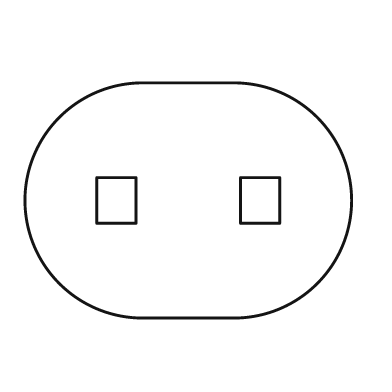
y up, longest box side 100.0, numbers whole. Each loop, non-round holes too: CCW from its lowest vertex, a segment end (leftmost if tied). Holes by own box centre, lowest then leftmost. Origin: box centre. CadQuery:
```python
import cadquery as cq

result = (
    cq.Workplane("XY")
    .moveTo(-14.0, -36.0)
    .lineTo(14.0, -36.0)
    .threePointArc((50.0, 0.0), (14.0, 36.0))
    .lineTo(-14.0, 36.0)
    .threePointArc((-50.0, 0.0), (-14.0, -36.0))
    .close()
    .moveTo(-28.0, -7.0)
    .lineTo(-16.0, -7.0)
    .lineTo(-16.0, 7.0)
    .lineTo(-28.0, 7.0)
    .close()
    .moveTo(16.0, -7.0)
    .lineTo(28.0, -7.0)
    .lineTo(28.0, 7.0)
    .lineTo(16.0, 7.0)
    .close()
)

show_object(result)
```